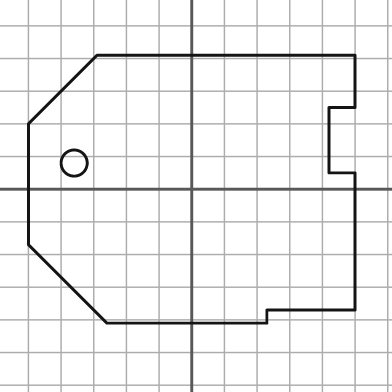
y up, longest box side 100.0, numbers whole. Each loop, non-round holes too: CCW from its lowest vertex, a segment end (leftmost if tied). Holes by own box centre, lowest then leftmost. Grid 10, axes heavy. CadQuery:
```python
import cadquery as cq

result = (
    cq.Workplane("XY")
    .moveTo(-26.0, -41.0)
    .lineTo(23.0, -41.0)
    .lineTo(23.0, -37.0)
    .lineTo(50.0, -37.0)
    .lineTo(50.0, 5.0)
    .lineTo(42.0, 5.0)
    .lineTo(42.0, 25.0)
    .lineTo(50.0, 25.0)
    .lineTo(50.0, 41.0)
    .lineTo(-29.0, 41.0)
    .lineTo(-50.0, 20.0)
    .lineTo(-50.0, -17.0)
    .close()
    .moveTo(-36.0, 8.0)
    .circle(4.0)
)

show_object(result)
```